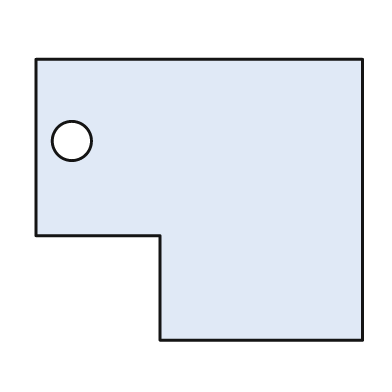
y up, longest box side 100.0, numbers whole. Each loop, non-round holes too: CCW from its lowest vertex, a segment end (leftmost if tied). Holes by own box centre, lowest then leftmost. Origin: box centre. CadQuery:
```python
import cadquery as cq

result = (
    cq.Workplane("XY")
    .moveTo(-12.0, -43.0)
    .lineTo(50.0, -43.0)
    .lineTo(50.0, 43.0)
    .lineTo(-50.0, 43.0)
    .lineTo(-50.0, -11.0)
    .lineTo(-12.0, -11.0)
    .close()
    .moveTo(-39.0, 18.0)
    .circle(6.0)
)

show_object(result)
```